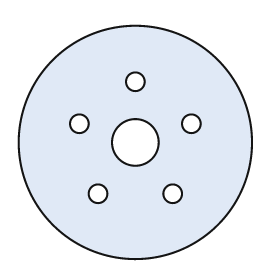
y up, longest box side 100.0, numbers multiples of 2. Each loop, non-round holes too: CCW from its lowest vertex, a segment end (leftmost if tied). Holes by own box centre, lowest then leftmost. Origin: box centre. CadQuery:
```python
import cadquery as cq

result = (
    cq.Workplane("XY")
    .moveTo(0.0, 0.0)
    .circle(50.0)
    .moveTo(-16.0, -22.0)
    .circle(4.0)
    .moveTo(16.0, -22.0)
    .circle(4.0)
    .moveTo(0.0, 0.0)
    .circle(10.0)
    .moveTo(-24.0, 8.0)
    .circle(4.0)
    .moveTo(24.0, 8.0)
    .circle(4.0)
    .moveTo(0.0, 26.0)
    .circle(4.0)
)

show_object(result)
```